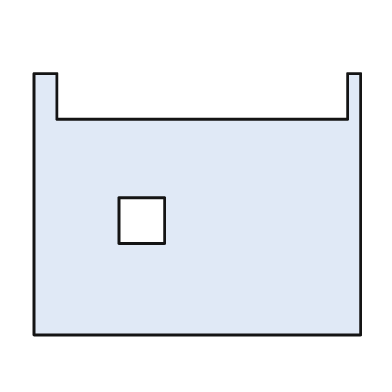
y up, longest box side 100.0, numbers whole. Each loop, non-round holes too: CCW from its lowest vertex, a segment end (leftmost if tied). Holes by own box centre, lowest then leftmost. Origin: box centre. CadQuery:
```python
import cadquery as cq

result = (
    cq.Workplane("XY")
    .moveTo(-50.0, -40.0)
    .lineTo(50.0, -40.0)
    .lineTo(50.0, 40.0)
    .lineTo(46.0, 40.0)
    .lineTo(46.0, 26.0)
    .lineTo(-43.0, 26.0)
    .lineTo(-43.0, 40.0)
    .lineTo(-50.0, 40.0)
    .close()
    .moveTo(-24.0, -12.0)
    .lineTo(-10.0, -12.0)
    .lineTo(-10.0, 2.0)
    .lineTo(-24.0, 2.0)
    .close()
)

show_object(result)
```